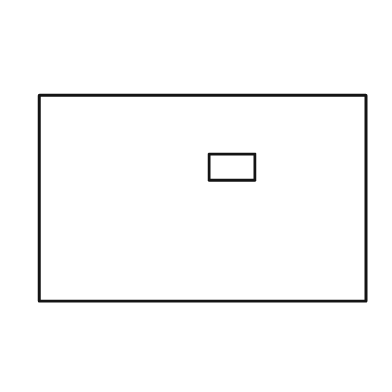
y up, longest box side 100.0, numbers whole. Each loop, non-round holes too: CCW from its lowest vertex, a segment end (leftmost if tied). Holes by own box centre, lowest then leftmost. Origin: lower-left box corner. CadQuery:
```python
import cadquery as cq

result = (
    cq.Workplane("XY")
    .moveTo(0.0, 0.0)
    .lineTo(100.0, 0.0)
    .lineTo(100.0, 63.0)
    .lineTo(0.0, 63.0)
    .close()
    .moveTo(52.0, 37.0)
    .lineTo(66.0, 37.0)
    .lineTo(66.0, 45.0)
    .lineTo(52.0, 45.0)
    .close()
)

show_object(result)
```